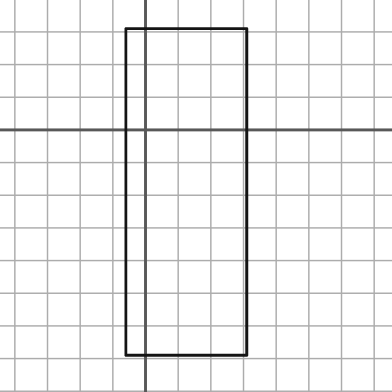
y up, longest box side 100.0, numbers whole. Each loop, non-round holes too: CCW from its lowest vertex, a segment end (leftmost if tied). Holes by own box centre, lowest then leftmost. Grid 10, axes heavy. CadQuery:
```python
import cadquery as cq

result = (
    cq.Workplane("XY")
    .moveTo(-6.0, -69.0)
    .lineTo(31.0, -69.0)
    .lineTo(31.0, 31.0)
    .lineTo(-6.0, 31.0)
    .close()
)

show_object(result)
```